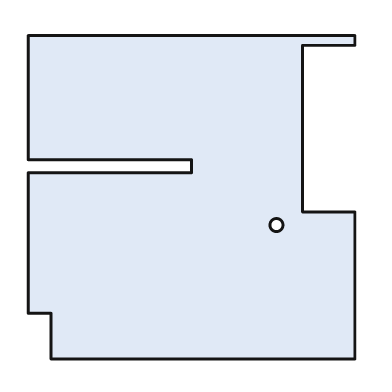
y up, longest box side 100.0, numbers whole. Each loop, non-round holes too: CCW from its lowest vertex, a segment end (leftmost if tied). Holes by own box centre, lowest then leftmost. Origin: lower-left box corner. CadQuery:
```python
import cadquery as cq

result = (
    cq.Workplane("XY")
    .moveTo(7.0, 0.0)
    .lineTo(100.0, 0.0)
    .lineTo(100.0, 45.0)
    .lineTo(84.0, 45.0)
    .lineTo(84.0, 96.0)
    .lineTo(100.0, 96.0)
    .lineTo(100.0, 99.0)
    .lineTo(0.0, 99.0)
    .lineTo(0.0, 61.0)
    .lineTo(50.0, 61.0)
    .lineTo(50.0, 57.0)
    .lineTo(0.0, 57.0)
    .lineTo(0.0, 14.0)
    .lineTo(7.0, 14.0)
    .close()
    .moveTo(76.0, 41.0)
    .circle(2.0)
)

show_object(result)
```